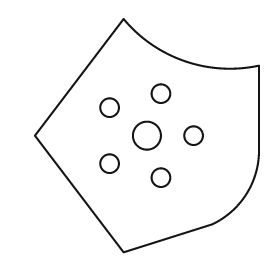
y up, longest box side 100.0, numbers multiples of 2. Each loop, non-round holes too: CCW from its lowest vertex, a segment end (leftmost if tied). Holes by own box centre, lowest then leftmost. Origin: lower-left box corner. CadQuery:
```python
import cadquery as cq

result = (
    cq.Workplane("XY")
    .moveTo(38.0, 0.0)
    .lineTo(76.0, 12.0)
    .threePointArc((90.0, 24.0), (96.0, 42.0))
    .lineTo(96.0, 80.0)
    .threePointArc((64.0, 82.0), (38.0, 100.0))
    .lineTo(0.0, 50.0)
    .close()
    .moveTo(54.0, 32.0)
    .circle(4.0)
    .moveTo(32.0, 38.0)
    .circle(4.0)
    .moveTo(48.0, 50.0)
    .circle(6.0)
    .moveTo(68.0, 50.0)
    .circle(4.0)
    .moveTo(32.0, 62.0)
    .circle(4.0)
    .moveTo(54.0, 68.0)
    .circle(4.0)
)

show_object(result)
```